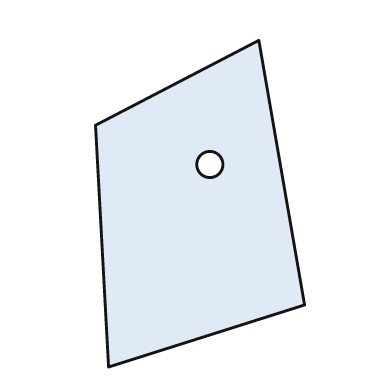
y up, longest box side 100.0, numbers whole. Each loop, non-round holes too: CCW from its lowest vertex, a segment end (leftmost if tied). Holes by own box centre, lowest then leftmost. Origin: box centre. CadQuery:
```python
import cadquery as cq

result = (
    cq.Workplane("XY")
    .moveTo(-28.0, -50.0)
    .lineTo(32.0, -31.0)
    .lineTo(18.0, 50.0)
    .lineTo(-32.0, 24.0)
    .close()
    .moveTo(3.0, 12.0)
    .circle(4.0)
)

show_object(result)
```